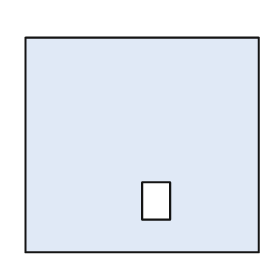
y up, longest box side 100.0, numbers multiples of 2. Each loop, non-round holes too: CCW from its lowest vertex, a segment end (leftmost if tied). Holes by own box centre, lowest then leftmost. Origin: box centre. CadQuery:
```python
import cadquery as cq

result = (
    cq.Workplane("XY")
    .moveTo(-50.0, -46.0)
    .lineTo(50.0, -46.0)
    .lineTo(50.0, 46.0)
    .lineTo(-50.0, 46.0)
    .close()
    .moveTo(0.0, -32.0)
    .lineTo(12.0, -32.0)
    .lineTo(12.0, -16.0)
    .lineTo(0.0, -16.0)
    .close()
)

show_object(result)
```